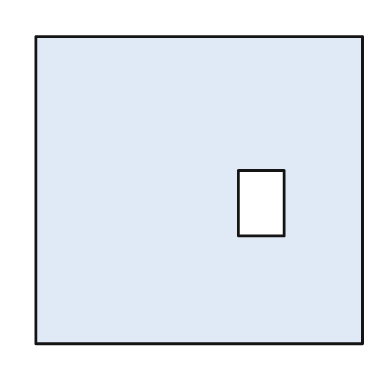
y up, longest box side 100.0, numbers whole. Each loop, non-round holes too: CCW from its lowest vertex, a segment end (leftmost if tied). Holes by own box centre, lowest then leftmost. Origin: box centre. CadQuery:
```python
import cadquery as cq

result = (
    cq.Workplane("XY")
    .moveTo(-50.0, -47.0)
    .lineTo(50.0, -47.0)
    .lineTo(50.0, 47.0)
    .lineTo(-50.0, 47.0)
    .close()
    .moveTo(12.0, -14.0)
    .lineTo(26.0, -14.0)
    .lineTo(26.0, 6.0)
    .lineTo(12.0, 6.0)
    .close()
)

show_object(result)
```